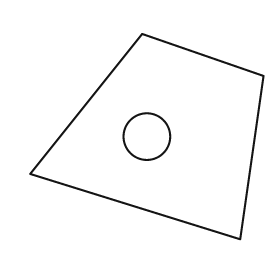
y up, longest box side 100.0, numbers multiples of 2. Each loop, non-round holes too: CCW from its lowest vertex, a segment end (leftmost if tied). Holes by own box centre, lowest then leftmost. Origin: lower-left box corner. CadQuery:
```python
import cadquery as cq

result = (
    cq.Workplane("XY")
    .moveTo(90.0, 0.0)
    .lineTo(100.0, 70.0)
    .lineTo(48.0, 88.0)
    .lineTo(0.0, 28.0)
    .close()
    .moveTo(50.0, 44.0)
    .circle(10.0)
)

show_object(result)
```